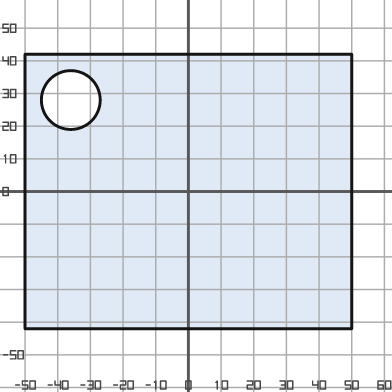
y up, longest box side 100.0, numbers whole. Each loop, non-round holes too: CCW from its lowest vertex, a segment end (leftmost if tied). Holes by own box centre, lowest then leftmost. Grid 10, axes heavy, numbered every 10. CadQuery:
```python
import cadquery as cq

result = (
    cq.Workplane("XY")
    .moveTo(-50.0, -42.0)
    .lineTo(50.0, -42.0)
    .lineTo(50.0, 42.0)
    .lineTo(-50.0, 42.0)
    .close()
    .moveTo(-36.0, 28.0)
    .circle(9.0)
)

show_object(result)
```